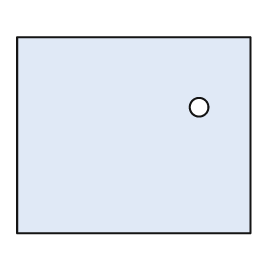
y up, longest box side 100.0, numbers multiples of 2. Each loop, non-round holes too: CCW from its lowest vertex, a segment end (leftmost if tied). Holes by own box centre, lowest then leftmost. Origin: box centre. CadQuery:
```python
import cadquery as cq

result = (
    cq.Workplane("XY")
    .moveTo(-50.0, -42.0)
    .lineTo(50.0, -42.0)
    .lineTo(50.0, 42.0)
    .lineTo(-50.0, 42.0)
    .close()
    .moveTo(28.0, 12.0)
    .circle(4.0)
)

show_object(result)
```